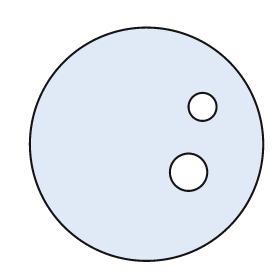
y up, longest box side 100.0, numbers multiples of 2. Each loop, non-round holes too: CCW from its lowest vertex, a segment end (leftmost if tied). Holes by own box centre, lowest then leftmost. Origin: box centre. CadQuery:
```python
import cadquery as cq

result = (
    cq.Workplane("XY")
    .moveTo(0.0, 0.0)
    .circle(50.0)
    .moveTo(18.0, -12.0)
    .circle(8.0)
    .moveTo(24.0, 16.0)
    .circle(6.0)
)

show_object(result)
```